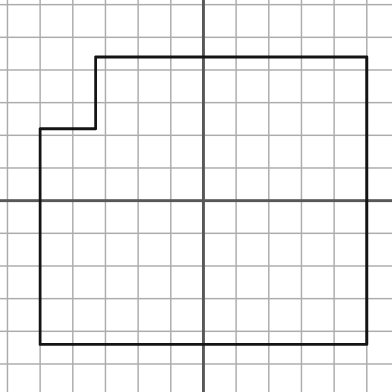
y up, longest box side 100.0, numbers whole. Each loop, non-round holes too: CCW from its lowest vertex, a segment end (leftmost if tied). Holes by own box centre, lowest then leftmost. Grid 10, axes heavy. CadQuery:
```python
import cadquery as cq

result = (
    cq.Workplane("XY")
    .moveTo(-50.0, -44.0)
    .lineTo(50.0, -44.0)
    .lineTo(50.0, 44.0)
    .lineTo(-33.0, 44.0)
    .lineTo(-33.0, 22.0)
    .lineTo(-50.0, 22.0)
    .close()
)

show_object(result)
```